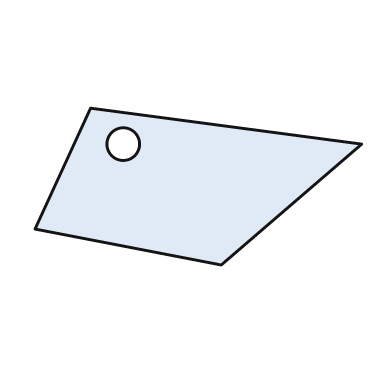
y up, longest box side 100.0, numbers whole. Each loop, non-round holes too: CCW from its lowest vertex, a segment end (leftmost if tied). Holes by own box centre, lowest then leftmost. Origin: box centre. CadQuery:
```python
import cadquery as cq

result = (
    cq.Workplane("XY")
    .moveTo(7.0, -24.0)
    .lineTo(50.0, 13.0)
    .lineTo(-33.0, 24.0)
    .lineTo(-50.0, -13.0)
    .close()
    .moveTo(-23.0, 13.0)
    .circle(5.0)
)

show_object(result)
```